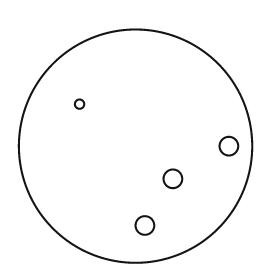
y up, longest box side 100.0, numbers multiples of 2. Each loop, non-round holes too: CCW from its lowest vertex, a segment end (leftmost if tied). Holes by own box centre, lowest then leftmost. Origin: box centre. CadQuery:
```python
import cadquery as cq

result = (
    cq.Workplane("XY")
    .moveTo(0.0, 0.0)
    .circle(50.0)
    .moveTo(4.0, -34.0)
    .circle(4.0)
    .moveTo(16.0, -14.0)
    .circle(4.0)
    .moveTo(40.0, 0.0)
    .circle(4.0)
    .moveTo(-24.0, 18.0)
    .circle(2.0)
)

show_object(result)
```